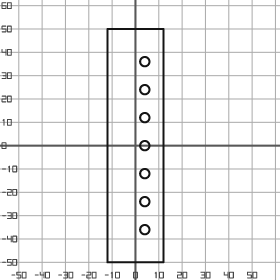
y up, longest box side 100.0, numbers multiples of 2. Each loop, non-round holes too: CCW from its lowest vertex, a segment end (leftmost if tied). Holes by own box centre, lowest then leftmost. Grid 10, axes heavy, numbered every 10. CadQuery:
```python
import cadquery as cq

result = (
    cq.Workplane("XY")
    .moveTo(-12.0, -50.0)
    .lineTo(12.0, -50.0)
    .lineTo(12.0, 50.0)
    .lineTo(-12.0, 50.0)
    .close()
    .moveTo(4.0, -36.0)
    .circle(2.0)
    .moveTo(4.0, -24.0)
    .circle(2.0)
    .moveTo(4.0, -12.0)
    .circle(2.0)
    .moveTo(4.0, 0.0)
    .circle(2.0)
    .moveTo(4.0, 12.0)
    .circle(2.0)
    .moveTo(4.0, 24.0)
    .circle(2.0)
    .moveTo(4.0, 36.0)
    .circle(2.0)
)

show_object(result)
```